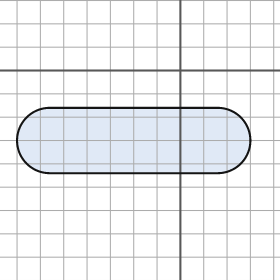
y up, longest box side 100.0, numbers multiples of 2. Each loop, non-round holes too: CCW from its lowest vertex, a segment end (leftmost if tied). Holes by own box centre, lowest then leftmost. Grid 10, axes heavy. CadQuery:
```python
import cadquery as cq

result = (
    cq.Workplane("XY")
    .moveTo(-56.0, -44.0)
    .lineTo(16.0, -44.0)
    .threePointArc((30.0, -30.0), (16.0, -16.0))
    .lineTo(-56.0, -16.0)
    .threePointArc((-70.0, -30.0), (-56.0, -44.0))
    .close()
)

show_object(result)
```